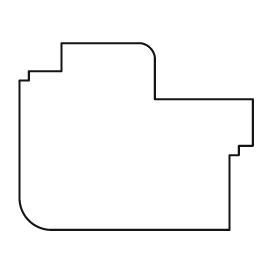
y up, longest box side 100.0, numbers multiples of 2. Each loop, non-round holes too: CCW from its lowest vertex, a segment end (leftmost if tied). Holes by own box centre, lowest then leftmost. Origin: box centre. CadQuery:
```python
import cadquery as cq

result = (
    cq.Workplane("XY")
    .moveTo(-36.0, -40.0)
    .lineTo(40.0, -40.0)
    .lineTo(40.0, -8.0)
    .lineTo(44.0, -8.0)
    .lineTo(44.0, -4.0)
    .lineTo(50.0, -4.0)
    .lineTo(50.0, 16.0)
    .lineTo(8.0, 16.0)
    .lineTo(8.0, 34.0)
    .threePointArc((6.0, 38.0), (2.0, 40.0))
    .lineTo(-32.0, 40.0)
    .lineTo(-32.0, 28.0)
    .lineTo(-46.0, 28.0)
    .lineTo(-46.0, 24.0)
    .lineTo(-50.0, 24.0)
    .lineTo(-50.0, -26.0)
    .threePointArc((-46.0, -36.0), (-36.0, -40.0))
    .close()
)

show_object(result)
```